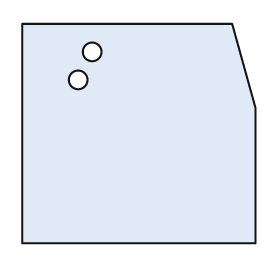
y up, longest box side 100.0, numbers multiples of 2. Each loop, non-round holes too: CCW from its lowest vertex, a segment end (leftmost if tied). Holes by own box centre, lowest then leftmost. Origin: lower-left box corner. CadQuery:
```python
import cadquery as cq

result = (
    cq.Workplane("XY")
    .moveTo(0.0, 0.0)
    .lineTo(100.0, 0.0)
    .lineTo(100.0, 58.0)
    .lineTo(90.0, 94.0)
    .lineTo(0.0, 94.0)
    .close()
    .moveTo(24.0, 70.0)
    .circle(4.0)
    .moveTo(30.0, 82.0)
    .circle(4.0)
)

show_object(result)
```